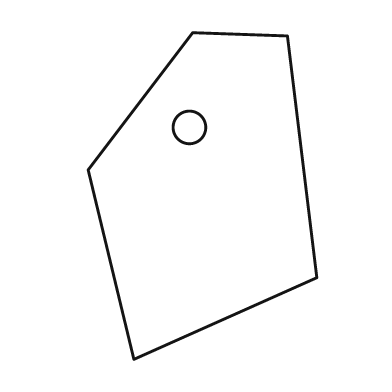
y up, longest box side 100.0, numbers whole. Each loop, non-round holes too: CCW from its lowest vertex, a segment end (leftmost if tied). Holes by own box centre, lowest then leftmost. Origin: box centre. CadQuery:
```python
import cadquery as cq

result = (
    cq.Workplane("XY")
    .moveTo(-21.0, -50.0)
    .lineTo(35.0, -25.0)
    .lineTo(26.0, 49.0)
    .lineTo(-3.0, 50.0)
    .lineTo(-35.0, 8.0)
    .close()
    .moveTo(-4.0, 21.0)
    .circle(5.0)
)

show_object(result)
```